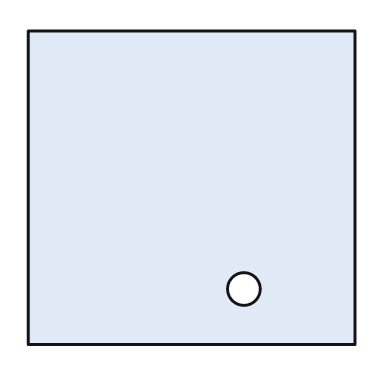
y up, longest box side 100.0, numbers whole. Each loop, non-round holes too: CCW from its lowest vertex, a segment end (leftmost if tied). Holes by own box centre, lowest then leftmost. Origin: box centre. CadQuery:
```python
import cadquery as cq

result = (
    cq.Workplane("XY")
    .moveTo(-50.0, -48.0)
    .lineTo(50.0, -48.0)
    .lineTo(50.0, 48.0)
    .lineTo(-50.0, 48.0)
    .close()
    .moveTo(16.0, -31.0)
    .circle(5.0)
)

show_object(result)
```